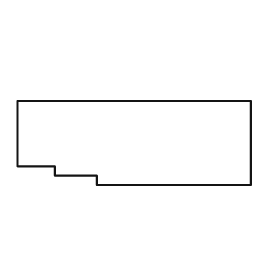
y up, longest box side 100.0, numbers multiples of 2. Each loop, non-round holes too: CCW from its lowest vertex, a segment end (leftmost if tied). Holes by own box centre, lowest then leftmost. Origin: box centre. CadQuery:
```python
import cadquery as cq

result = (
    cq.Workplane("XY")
    .moveTo(-16.0, -18.0)
    .lineTo(50.0, -18.0)
    .lineTo(50.0, 18.0)
    .lineTo(-50.0, 18.0)
    .lineTo(-50.0, -10.0)
    .lineTo(-34.0, -10.0)
    .lineTo(-34.0, -14.0)
    .lineTo(-16.0, -14.0)
    .close()
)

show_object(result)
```